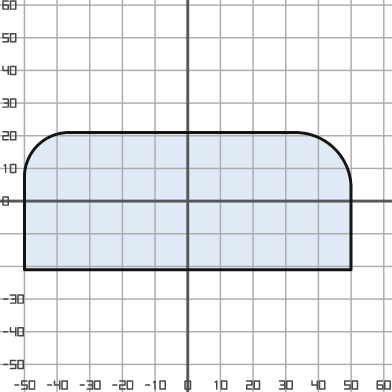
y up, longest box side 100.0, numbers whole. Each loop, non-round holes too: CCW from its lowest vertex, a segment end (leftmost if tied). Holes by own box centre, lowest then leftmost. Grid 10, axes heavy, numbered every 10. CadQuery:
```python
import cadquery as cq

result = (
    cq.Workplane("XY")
    .moveTo(-50.0, -21.0)
    .lineTo(50.0, -21.0)
    .lineTo(50.0, 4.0)
    .threePointArc((45.0, 16.0), (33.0, 21.0))
    .lineTo(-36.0, 21.0)
    .threePointArc((-46.0, 17.0), (-50.0, 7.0))
    .close()
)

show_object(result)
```